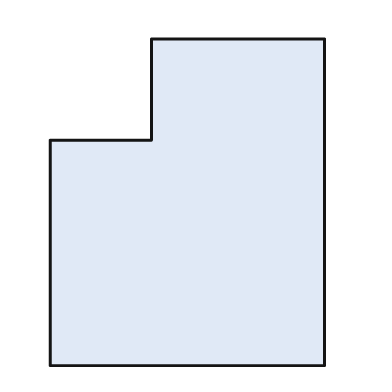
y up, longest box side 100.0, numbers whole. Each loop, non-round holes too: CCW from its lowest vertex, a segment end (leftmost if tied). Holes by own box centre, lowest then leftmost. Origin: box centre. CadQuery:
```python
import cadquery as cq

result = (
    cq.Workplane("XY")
    .moveTo(-42.0, -50.0)
    .lineTo(42.0, -50.0)
    .lineTo(42.0, 50.0)
    .lineTo(-11.0, 50.0)
    .lineTo(-11.0, 19.0)
    .lineTo(-42.0, 19.0)
    .close()
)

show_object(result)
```